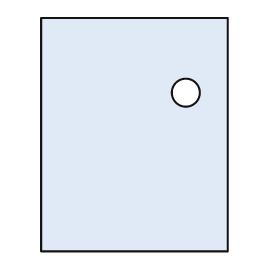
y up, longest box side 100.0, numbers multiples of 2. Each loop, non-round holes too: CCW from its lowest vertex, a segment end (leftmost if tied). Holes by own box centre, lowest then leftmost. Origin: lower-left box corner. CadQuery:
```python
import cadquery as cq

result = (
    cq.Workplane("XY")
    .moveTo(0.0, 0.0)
    .lineTo(80.0, 0.0)
    .lineTo(80.0, 100.0)
    .lineTo(0.0, 100.0)
    .close()
    .moveTo(62.0, 68.0)
    .circle(6.0)
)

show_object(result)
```